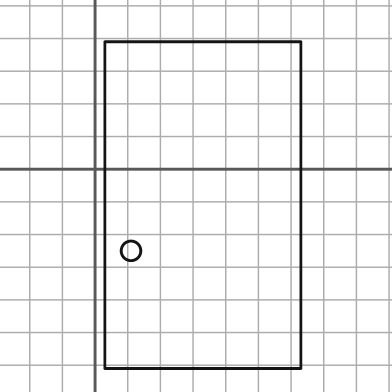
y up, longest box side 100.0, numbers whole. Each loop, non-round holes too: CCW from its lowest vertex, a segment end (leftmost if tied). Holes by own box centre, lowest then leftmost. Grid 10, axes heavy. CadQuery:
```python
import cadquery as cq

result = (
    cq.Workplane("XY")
    .moveTo(3.0, -61.0)
    .lineTo(63.0, -61.0)
    .lineTo(63.0, 39.0)
    .lineTo(3.0, 39.0)
    .close()
    .moveTo(11.0, -25.0)
    .circle(3.0)
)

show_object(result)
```